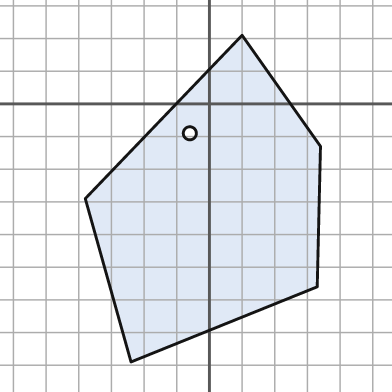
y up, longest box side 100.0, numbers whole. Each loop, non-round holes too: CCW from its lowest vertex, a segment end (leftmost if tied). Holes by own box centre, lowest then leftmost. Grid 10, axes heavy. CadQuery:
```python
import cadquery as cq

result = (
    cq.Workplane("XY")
    .moveTo(-24.0, -79.0)
    .lineTo(33.0, -56.0)
    .lineTo(34.0, -13.0)
    .lineTo(10.0, 21.0)
    .lineTo(-38.0, -29.0)
    .close()
    .moveTo(-6.0, -9.0)
    .circle(2.0)
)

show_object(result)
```